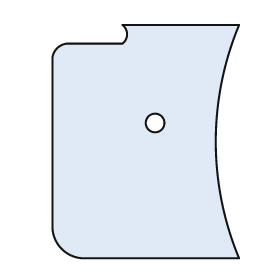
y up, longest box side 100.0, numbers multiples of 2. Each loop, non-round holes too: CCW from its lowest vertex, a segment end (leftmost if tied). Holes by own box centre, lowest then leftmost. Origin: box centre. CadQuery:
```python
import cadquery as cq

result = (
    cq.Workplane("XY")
    .moveTo(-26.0, -50.0)
    .lineTo(40.0, -50.0)
    .threePointArc((30.0, 0.0), (40.0, 50.0))
    .lineTo(-10.0, 50.0)
    .threePointArc((-8.0, 46.0), (-10.0, 42.0))
    .lineTo(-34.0, 42.0)
    .threePointArc((-38.0, 40.0), (-40.0, 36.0))
    .lineTo(-40.0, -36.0)
    .threePointArc((-36.0, -46.0), (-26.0, -50.0))
    .close()
    .moveTo(4.0, 8.0)
    .circle(4.0)
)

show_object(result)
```